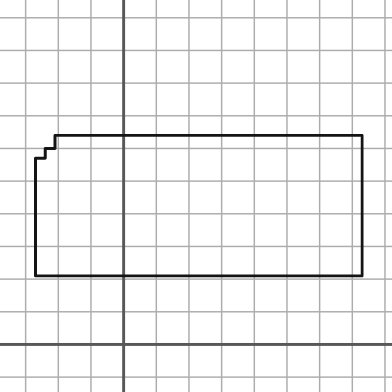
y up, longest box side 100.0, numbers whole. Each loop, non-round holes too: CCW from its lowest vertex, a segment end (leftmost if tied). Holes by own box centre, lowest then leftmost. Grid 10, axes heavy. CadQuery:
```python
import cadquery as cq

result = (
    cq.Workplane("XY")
    .moveTo(-27.0, 21.0)
    .lineTo(73.0, 21.0)
    .lineTo(73.0, 64.0)
    .lineTo(-21.0, 64.0)
    .lineTo(-21.0, 60.0)
    .lineTo(-24.0, 60.0)
    .lineTo(-24.0, 57.0)
    .lineTo(-27.0, 57.0)
    .close()
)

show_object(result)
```